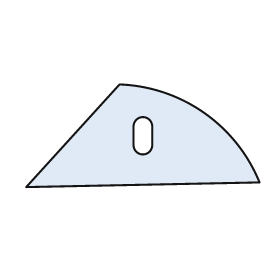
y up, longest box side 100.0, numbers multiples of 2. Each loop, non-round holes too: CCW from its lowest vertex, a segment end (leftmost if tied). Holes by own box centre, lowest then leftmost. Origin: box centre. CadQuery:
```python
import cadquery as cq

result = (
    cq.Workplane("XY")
    .moveTo(-50.0, -22.0)
    .lineTo(50.0, -20.0)
    .threePointArc((26.0, 10.0), (-10.0, 22.0))
    .close()
    .moveTo(-4.0, -4.0)
    .threePointArc((0.0, -8.0), (4.0, -4.0))
    .lineTo(4.0, 4.0)
    .threePointArc((0.0, 8.0), (-4.0, 4.0))
    .close()
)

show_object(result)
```